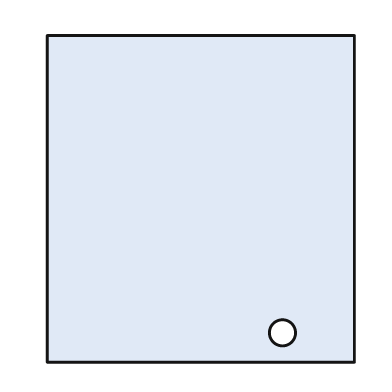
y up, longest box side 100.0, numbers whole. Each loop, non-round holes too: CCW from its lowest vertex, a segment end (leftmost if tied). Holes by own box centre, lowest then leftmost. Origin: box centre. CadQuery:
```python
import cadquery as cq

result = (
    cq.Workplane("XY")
    .moveTo(-47.0, -50.0)
    .lineTo(47.0, -50.0)
    .lineTo(47.0, 50.0)
    .lineTo(-47.0, 50.0)
    .close()
    .moveTo(25.0, -41.0)
    .circle(4.0)
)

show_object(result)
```